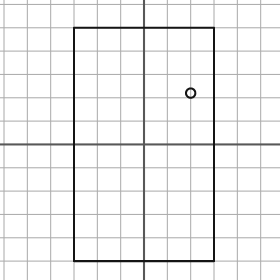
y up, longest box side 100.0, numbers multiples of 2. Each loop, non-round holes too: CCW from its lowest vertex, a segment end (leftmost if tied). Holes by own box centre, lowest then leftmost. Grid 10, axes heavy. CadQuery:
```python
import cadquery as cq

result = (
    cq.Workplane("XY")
    .moveTo(-30.0, -50.0)
    .lineTo(30.0, -50.0)
    .lineTo(30.0, 50.0)
    .lineTo(-30.0, 50.0)
    .close()
    .moveTo(20.0, 22.0)
    .circle(2.0)
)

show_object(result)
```